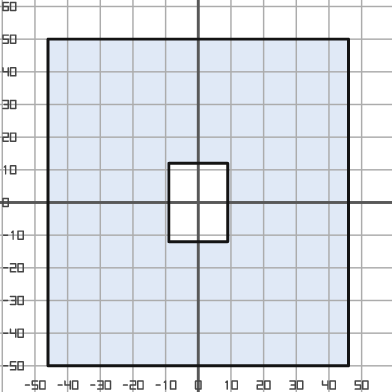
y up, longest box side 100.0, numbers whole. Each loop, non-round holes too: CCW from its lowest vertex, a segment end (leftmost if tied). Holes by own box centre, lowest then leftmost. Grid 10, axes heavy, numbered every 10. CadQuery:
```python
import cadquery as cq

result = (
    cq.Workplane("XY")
    .moveTo(-46.0, -50.0)
    .lineTo(46.0, -50.0)
    .lineTo(46.0, 50.0)
    .lineTo(-46.0, 50.0)
    .close()
    .moveTo(-9.0, -12.0)
    .lineTo(9.0, -12.0)
    .lineTo(9.0, 12.0)
    .lineTo(-9.0, 12.0)
    .close()
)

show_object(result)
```